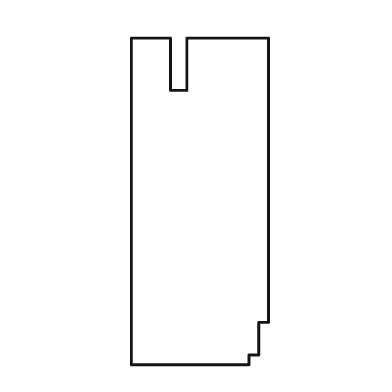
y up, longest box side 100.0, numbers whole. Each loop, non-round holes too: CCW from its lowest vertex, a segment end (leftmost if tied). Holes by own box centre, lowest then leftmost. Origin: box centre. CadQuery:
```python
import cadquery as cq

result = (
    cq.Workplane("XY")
    .moveTo(-21.0, -50.0)
    .lineTo(15.0, -50.0)
    .lineTo(15.0, -47.0)
    .lineTo(18.0, -47.0)
    .lineTo(18.0, -37.0)
    .lineTo(21.0, -37.0)
    .lineTo(21.0, 50.0)
    .lineTo(-4.0, 50.0)
    .lineTo(-4.0, 34.0)
    .lineTo(-9.0, 34.0)
    .lineTo(-9.0, 50.0)
    .lineTo(-21.0, 50.0)
    .close()
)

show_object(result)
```